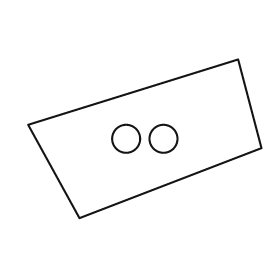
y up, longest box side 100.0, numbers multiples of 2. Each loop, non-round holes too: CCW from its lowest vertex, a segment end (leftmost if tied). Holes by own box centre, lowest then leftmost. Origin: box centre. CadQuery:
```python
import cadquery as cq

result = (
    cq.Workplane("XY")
    .moveTo(-28.0, -34.0)
    .lineTo(50.0, -4.0)
    .lineTo(40.0, 34.0)
    .lineTo(-50.0, 6.0)
    .close()
    .moveTo(-8.0, 0.0)
    .circle(6.0)
    .moveTo(8.0, 0.0)
    .circle(6.0)
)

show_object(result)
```